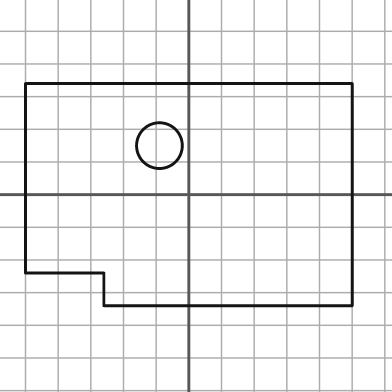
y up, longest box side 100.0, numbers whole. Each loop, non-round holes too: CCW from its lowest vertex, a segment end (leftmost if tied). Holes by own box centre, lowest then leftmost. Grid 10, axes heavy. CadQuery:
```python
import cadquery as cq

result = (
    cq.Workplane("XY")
    .moveTo(-26.0, -34.0)
    .lineTo(50.0, -34.0)
    .lineTo(50.0, 34.0)
    .lineTo(-50.0, 34.0)
    .lineTo(-50.0, -24.0)
    .lineTo(-26.0, -24.0)
    .close()
    .moveTo(-9.0, 15.0)
    .circle(7.0)
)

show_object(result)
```